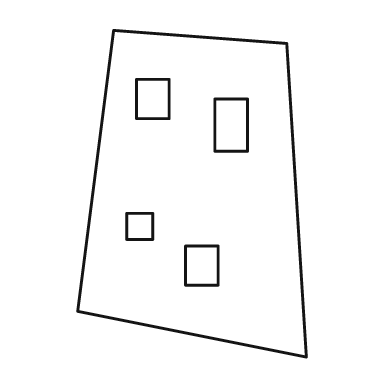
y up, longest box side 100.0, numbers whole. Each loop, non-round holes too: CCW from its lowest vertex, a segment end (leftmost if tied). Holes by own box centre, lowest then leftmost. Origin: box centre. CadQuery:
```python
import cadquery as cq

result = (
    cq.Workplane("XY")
    .moveTo(35.0, -50.0)
    .lineTo(29.0, 46.0)
    .lineTo(-24.0, 50.0)
    .lineTo(-35.0, -36.0)
    .close()
    .moveTo(-2.0, -28.0)
    .lineTo(8.0, -28.0)
    .lineTo(8.0, -16.0)
    .lineTo(-2.0, -16.0)
    .close()
    .moveTo(-20.0, -14.0)
    .lineTo(-12.0, -14.0)
    .lineTo(-12.0, -6.0)
    .lineTo(-20.0, -6.0)
    .close()
    .moveTo(7.0, 13.0)
    .lineTo(17.0, 13.0)
    .lineTo(17.0, 29.0)
    .lineTo(7.0, 29.0)
    .close()
    .moveTo(-17.0, 23.0)
    .lineTo(-7.0, 23.0)
    .lineTo(-7.0, 35.0)
    .lineTo(-17.0, 35.0)
    .close()
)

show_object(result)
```